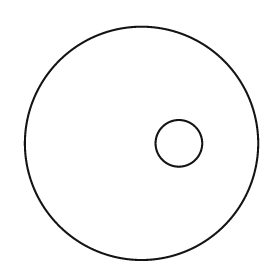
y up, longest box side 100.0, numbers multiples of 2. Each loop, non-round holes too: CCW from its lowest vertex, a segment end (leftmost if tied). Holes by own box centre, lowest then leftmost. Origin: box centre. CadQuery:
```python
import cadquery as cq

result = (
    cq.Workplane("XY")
    .moveTo(0.0, 0.0)
    .circle(50.0)
    .moveTo(16.0, 0.0)
    .circle(10.0)
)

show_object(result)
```